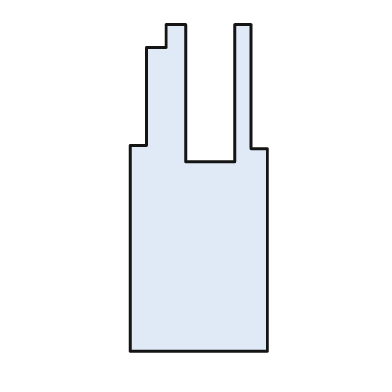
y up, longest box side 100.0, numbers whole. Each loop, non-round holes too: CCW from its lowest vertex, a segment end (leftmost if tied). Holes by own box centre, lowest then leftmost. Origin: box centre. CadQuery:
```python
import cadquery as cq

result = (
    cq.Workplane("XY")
    .moveTo(-21.0, -50.0)
    .lineTo(21.0, -50.0)
    .lineTo(21.0, 12.0)
    .lineTo(16.0, 12.0)
    .lineTo(16.0, 50.0)
    .lineTo(11.0, 50.0)
    .lineTo(11.0, 8.0)
    .lineTo(-4.0, 8.0)
    .lineTo(-4.0, 50.0)
    .lineTo(-10.0, 50.0)
    .lineTo(-10.0, 43.0)
    .lineTo(-16.0, 43.0)
    .lineTo(-16.0, 13.0)
    .lineTo(-21.0, 13.0)
    .close()
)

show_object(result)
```